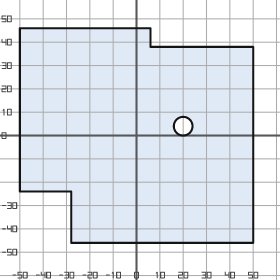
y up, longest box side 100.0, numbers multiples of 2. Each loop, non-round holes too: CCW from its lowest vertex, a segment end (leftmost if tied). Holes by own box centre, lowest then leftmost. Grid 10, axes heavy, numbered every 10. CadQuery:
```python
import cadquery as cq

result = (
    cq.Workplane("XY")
    .moveTo(-28.0, -46.0)
    .lineTo(50.0, -46.0)
    .lineTo(50.0, 38.0)
    .lineTo(6.0, 38.0)
    .lineTo(6.0, 46.0)
    .lineTo(-50.0, 46.0)
    .lineTo(-50.0, -24.0)
    .lineTo(-28.0, -24.0)
    .close()
    .moveTo(20.0, 4.0)
    .circle(4.0)
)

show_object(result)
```